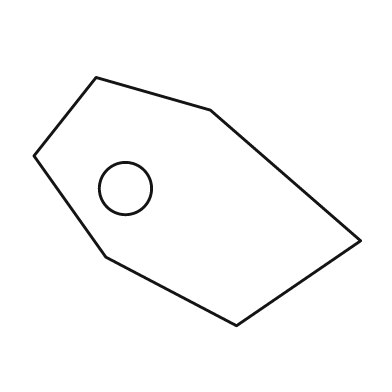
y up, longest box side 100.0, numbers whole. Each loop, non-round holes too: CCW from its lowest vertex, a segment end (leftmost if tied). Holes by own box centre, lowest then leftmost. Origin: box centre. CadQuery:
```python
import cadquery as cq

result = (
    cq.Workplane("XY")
    .moveTo(12.0, -38.0)
    .lineTo(50.0, -12.0)
    .lineTo(4.0, 28.0)
    .lineTo(-31.0, 38.0)
    .lineTo(-50.0, 14.0)
    .lineTo(-28.0, -17.0)
    .close()
    .moveTo(-22.0, 4.0)
    .circle(8.0)
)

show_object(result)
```